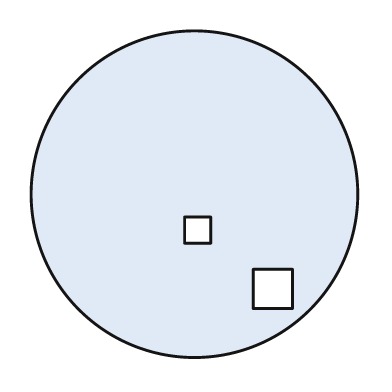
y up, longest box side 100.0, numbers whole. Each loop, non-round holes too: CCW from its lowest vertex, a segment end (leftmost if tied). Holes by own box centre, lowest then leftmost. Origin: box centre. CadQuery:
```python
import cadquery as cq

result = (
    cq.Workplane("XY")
    .moveTo(0.0, 0.0)
    .circle(50.0)
    .moveTo(18.0, -35.0)
    .lineTo(30.0, -35.0)
    .lineTo(30.0, -23.0)
    .lineTo(18.0, -23.0)
    .close()
    .moveTo(-3.0, -15.0)
    .lineTo(5.0, -15.0)
    .lineTo(5.0, -7.0)
    .lineTo(-3.0, -7.0)
    .close()
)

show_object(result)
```